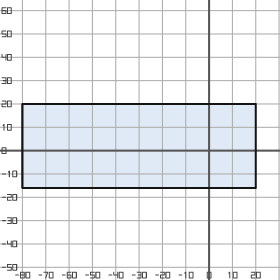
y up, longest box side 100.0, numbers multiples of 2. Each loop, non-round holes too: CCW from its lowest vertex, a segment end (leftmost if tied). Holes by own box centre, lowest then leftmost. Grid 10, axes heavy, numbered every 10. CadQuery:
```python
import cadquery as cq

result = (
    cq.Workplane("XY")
    .moveTo(-80.0, -16.0)
    .lineTo(20.0, -16.0)
    .lineTo(20.0, 20.0)
    .lineTo(-80.0, 20.0)
    .close()
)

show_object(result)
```